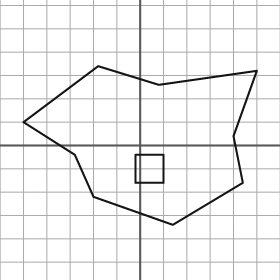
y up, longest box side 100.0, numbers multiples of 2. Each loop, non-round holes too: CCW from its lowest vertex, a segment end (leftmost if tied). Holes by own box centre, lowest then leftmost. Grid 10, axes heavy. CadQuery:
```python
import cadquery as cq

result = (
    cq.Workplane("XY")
    .moveTo(14.0, -34.0)
    .lineTo(44.0, -16.0)
    .lineTo(40.0, 4.0)
    .lineTo(50.0, 32.0)
    .lineTo(8.0, 26.0)
    .lineTo(-18.0, 34.0)
    .lineTo(-50.0, 10.0)
    .lineTo(-28.0, -4.0)
    .lineTo(-20.0, -22.0)
    .close()
    .moveTo(-2.0, -16.0)
    .lineTo(10.0, -16.0)
    .lineTo(10.0, -4.0)
    .lineTo(-2.0, -4.0)
    .close()
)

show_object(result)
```